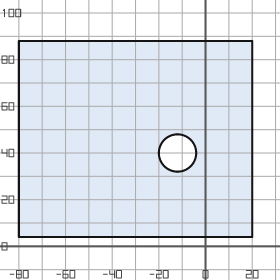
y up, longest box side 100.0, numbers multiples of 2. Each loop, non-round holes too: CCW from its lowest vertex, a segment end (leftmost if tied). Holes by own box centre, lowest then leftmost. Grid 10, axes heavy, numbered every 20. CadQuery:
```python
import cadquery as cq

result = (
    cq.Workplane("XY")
    .moveTo(-80.0, 4.0)
    .lineTo(20.0, 4.0)
    .lineTo(20.0, 88.0)
    .lineTo(-80.0, 88.0)
    .close()
    .moveTo(-12.0, 40.0)
    .circle(8.0)
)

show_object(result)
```